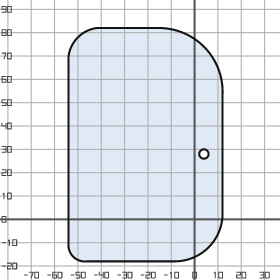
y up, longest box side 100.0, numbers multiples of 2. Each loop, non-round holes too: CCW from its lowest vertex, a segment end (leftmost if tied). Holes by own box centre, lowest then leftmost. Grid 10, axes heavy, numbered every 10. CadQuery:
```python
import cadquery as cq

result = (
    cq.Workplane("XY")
    .moveTo(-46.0, -18.0)
    .lineTo(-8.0, -18.0)
    .threePointArc((6.0, -12.0), (12.0, 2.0))
    .lineTo(12.0, 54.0)
    .threePointArc((4.0, 74.0), (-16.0, 82.0))
    .lineTo(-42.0, 82.0)
    .threePointArc((-50.0, 78.0), (-54.0, 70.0))
    .lineTo(-54.0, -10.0)
    .threePointArc((-52.0, -16.0), (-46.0, -18.0))
    .close()
    .moveTo(4.0, 28.0)
    .circle(2.0)
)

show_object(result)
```